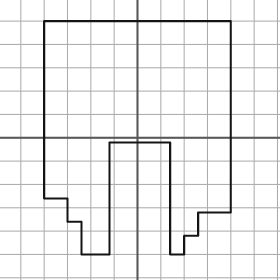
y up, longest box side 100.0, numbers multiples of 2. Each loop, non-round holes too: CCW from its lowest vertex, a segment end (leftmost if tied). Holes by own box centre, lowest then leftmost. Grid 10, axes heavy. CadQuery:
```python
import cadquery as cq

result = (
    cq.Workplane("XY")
    .moveTo(-24.0, -50.0)
    .lineTo(-12.0, -50.0)
    .lineTo(-12.0, -2.0)
    .lineTo(14.0, -2.0)
    .lineTo(14.0, -50.0)
    .lineTo(20.0, -50.0)
    .lineTo(20.0, -42.0)
    .lineTo(26.0, -42.0)
    .lineTo(26.0, -32.0)
    .lineTo(40.0, -32.0)
    .lineTo(40.0, 50.0)
    .lineTo(-40.0, 50.0)
    .lineTo(-40.0, -26.0)
    .lineTo(-30.0, -26.0)
    .lineTo(-30.0, -36.0)
    .lineTo(-24.0, -36.0)
    .close()
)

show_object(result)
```